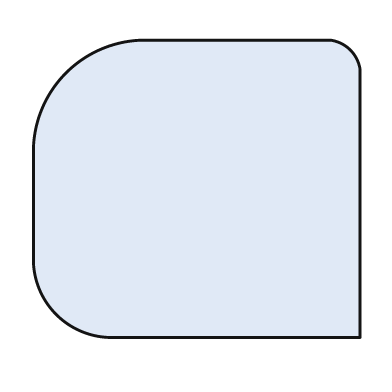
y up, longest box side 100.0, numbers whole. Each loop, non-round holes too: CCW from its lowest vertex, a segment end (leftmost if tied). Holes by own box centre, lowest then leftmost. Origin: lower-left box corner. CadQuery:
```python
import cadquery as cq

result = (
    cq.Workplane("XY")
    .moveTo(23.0, 0.0)
    .lineTo(100.0, 0.0)
    .lineTo(100.0, 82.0)
    .threePointArc((97.0, 88.0), (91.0, 91.0))
    .lineTo(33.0, 91.0)
    .threePointArc((10.0, 81.0), (0.0, 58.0))
    .lineTo(0.0, 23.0)
    .threePointArc((7.0, 7.0), (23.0, 0.0))
    .close()
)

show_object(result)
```